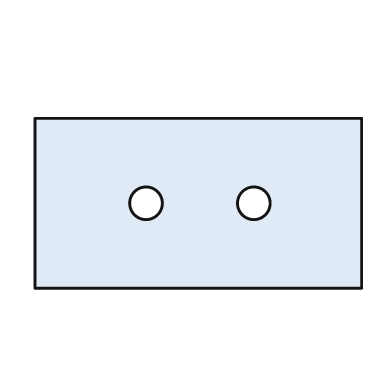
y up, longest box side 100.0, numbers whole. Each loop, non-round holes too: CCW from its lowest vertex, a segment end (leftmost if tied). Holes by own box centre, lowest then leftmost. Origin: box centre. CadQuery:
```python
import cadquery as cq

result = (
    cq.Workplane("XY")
    .moveTo(-50.0, -26.0)
    .lineTo(50.0, -26.0)
    .lineTo(50.0, 26.0)
    .lineTo(-50.0, 26.0)
    .close()
    .moveTo(-16.0, 0.0)
    .circle(5.0)
    .moveTo(17.0, 0.0)
    .circle(5.0)
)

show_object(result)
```